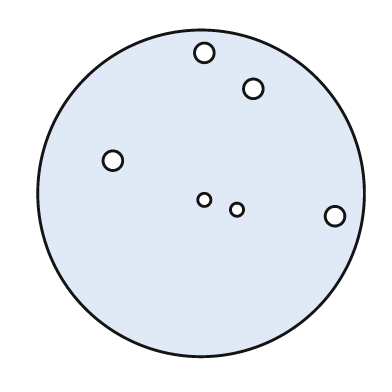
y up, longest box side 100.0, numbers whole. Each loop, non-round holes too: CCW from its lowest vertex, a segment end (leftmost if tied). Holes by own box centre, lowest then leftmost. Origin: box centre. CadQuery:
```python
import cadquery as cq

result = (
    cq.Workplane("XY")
    .moveTo(0.0, 0.0)
    .circle(50.0)
    .moveTo(41.0, -7.0)
    .circle(3.0)
    .moveTo(11.0, -5.0)
    .circle(2.0)
    .moveTo(1.0, -2.0)
    .circle(2.0)
    .moveTo(-27.0, 10.0)
    .circle(3.0)
    .moveTo(16.0, 32.0)
    .circle(3.0)
    .moveTo(1.0, 43.0)
    .circle(3.0)
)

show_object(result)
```